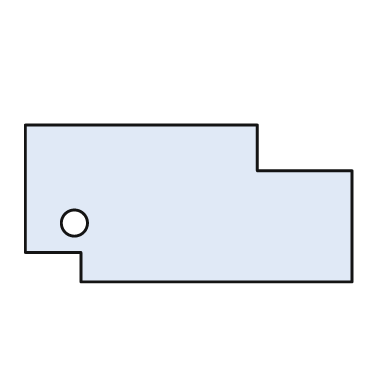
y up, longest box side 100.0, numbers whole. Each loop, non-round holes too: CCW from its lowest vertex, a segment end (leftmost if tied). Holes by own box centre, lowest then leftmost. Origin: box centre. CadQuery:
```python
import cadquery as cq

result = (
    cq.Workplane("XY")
    .moveTo(-33.0, -24.0)
    .lineTo(50.0, -24.0)
    .lineTo(50.0, 10.0)
    .lineTo(21.0, 10.0)
    .lineTo(21.0, 24.0)
    .lineTo(-50.0, 24.0)
    .lineTo(-50.0, -15.0)
    .lineTo(-33.0, -15.0)
    .close()
    .moveTo(-35.0, -6.0)
    .circle(4.0)
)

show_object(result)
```